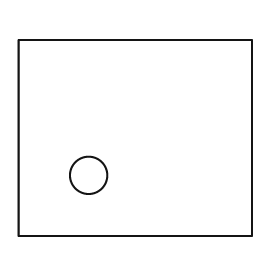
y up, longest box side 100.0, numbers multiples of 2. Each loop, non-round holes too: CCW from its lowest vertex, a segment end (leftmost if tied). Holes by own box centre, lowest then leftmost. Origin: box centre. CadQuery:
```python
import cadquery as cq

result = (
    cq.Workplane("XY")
    .moveTo(-50.0, -42.0)
    .lineTo(50.0, -42.0)
    .lineTo(50.0, 42.0)
    .lineTo(-50.0, 42.0)
    .close()
    .moveTo(-20.0, -16.0)
    .circle(8.0)
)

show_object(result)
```